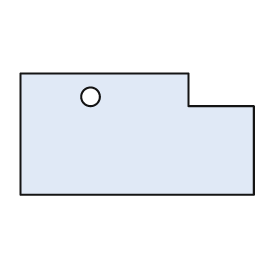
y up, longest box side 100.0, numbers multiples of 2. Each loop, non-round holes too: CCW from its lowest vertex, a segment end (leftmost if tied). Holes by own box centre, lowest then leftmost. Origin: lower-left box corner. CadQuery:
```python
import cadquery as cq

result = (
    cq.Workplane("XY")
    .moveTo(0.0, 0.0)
    .lineTo(100.0, 0.0)
    .lineTo(100.0, 38.0)
    .lineTo(72.0, 38.0)
    .lineTo(72.0, 52.0)
    .lineTo(0.0, 52.0)
    .close()
    .moveTo(30.0, 42.0)
    .circle(4.0)
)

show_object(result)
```